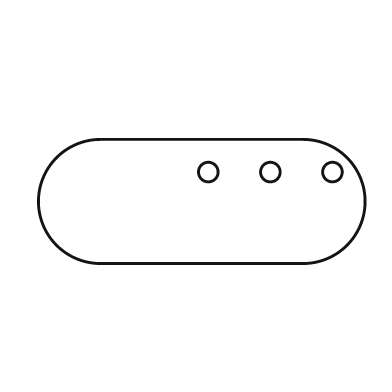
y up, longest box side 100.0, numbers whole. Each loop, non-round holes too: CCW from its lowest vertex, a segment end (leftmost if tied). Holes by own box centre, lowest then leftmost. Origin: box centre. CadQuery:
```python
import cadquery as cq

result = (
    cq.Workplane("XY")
    .moveTo(-31.0, -19.0)
    .lineTo(31.0, -19.0)
    .threePointArc((50.0, 0.0), (31.0, 19.0))
    .lineTo(-31.0, 19.0)
    .threePointArc((-50.0, 0.0), (-31.0, -19.0))
    .close()
    .moveTo(2.0, 9.0)
    .circle(3.0)
    .moveTo(21.0, 9.0)
    .circle(3.0)
    .moveTo(40.0, 9.0)
    .circle(3.0)
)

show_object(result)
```